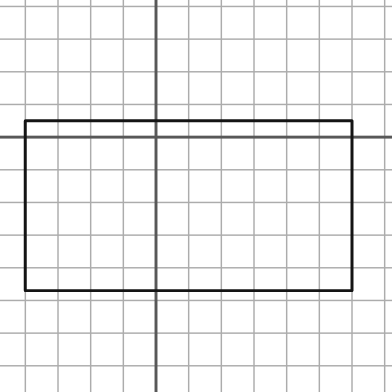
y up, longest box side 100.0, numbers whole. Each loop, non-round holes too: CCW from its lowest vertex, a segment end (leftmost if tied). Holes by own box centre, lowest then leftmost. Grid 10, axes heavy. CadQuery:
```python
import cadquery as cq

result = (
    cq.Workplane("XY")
    .moveTo(-40.0, -47.0)
    .lineTo(60.0, -47.0)
    .lineTo(60.0, 5.0)
    .lineTo(-40.0, 5.0)
    .close()
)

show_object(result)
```